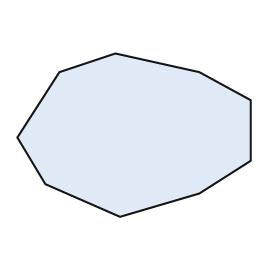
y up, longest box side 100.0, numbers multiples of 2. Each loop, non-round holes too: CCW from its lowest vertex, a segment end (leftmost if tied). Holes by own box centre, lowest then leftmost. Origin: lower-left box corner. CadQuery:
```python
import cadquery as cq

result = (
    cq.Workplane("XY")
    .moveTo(44.0, 0.0)
    .lineTo(78.0, 10.0)
    .lineTo(100.0, 24.0)
    .lineTo(100.0, 50.0)
    .lineTo(78.0, 62.0)
    .lineTo(42.0, 70.0)
    .lineTo(18.0, 62.0)
    .lineTo(0.0, 34.0)
    .lineTo(12.0, 14.0)
    .close()
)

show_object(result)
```